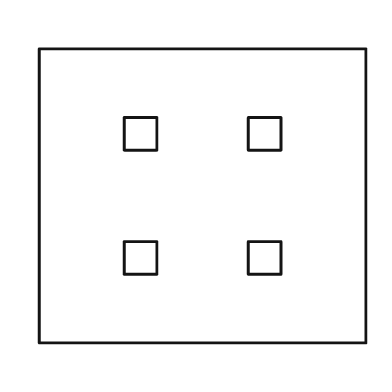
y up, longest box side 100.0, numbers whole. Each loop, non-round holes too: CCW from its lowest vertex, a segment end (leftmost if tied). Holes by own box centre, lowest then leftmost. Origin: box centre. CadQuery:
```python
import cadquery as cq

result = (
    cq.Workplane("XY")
    .moveTo(-50.0, -45.0)
    .lineTo(50.0, -45.0)
    .lineTo(50.0, 45.0)
    .lineTo(-50.0, 45.0)
    .close()
    .moveTo(-24.0, -24.0)
    .lineTo(-14.0, -24.0)
    .lineTo(-14.0, -14.0)
    .lineTo(-24.0, -14.0)
    .close()
    .moveTo(14.0, -24.0)
    .lineTo(24.0, -24.0)
    .lineTo(24.0, -14.0)
    .lineTo(14.0, -14.0)
    .close()
    .moveTo(-24.0, 14.0)
    .lineTo(-14.0, 14.0)
    .lineTo(-14.0, 24.0)
    .lineTo(-24.0, 24.0)
    .close()
    .moveTo(14.0, 14.0)
    .lineTo(24.0, 14.0)
    .lineTo(24.0, 24.0)
    .lineTo(14.0, 24.0)
    .close()
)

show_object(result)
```